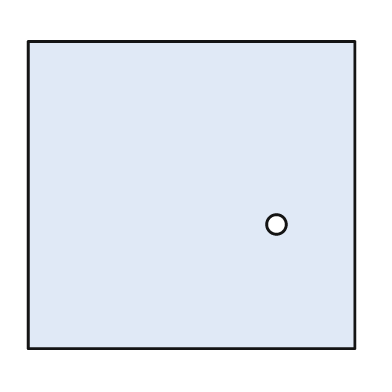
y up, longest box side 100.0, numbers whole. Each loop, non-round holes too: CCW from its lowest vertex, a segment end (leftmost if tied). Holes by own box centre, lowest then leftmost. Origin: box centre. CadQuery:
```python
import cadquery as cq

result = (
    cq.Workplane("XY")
    .moveTo(-50.0, -47.0)
    .lineTo(50.0, -47.0)
    .lineTo(50.0, 47.0)
    .lineTo(-50.0, 47.0)
    .close()
    .moveTo(26.0, -9.0)
    .circle(3.0)
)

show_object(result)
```